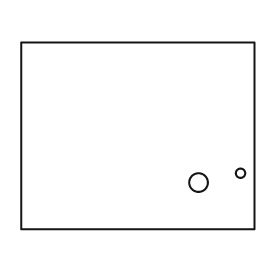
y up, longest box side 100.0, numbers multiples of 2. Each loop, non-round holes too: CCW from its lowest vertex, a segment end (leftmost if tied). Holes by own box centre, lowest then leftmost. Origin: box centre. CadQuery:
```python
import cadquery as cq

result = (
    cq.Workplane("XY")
    .moveTo(-50.0, -40.0)
    .lineTo(50.0, -40.0)
    .lineTo(50.0, 40.0)
    .lineTo(-50.0, 40.0)
    .close()
    .moveTo(26.0, -20.0)
    .circle(4.0)
    .moveTo(44.0, -16.0)
    .circle(2.0)
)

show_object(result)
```